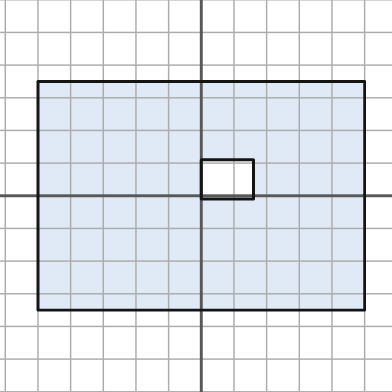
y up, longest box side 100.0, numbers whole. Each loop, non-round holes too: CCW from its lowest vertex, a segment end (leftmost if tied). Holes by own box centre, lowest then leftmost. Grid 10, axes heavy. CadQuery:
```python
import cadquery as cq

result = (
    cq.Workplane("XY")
    .moveTo(-50.0, -35.0)
    .lineTo(50.0, -35.0)
    .lineTo(50.0, 35.0)
    .lineTo(-50.0, 35.0)
    .close()
    .moveTo(0.0, -1.0)
    .lineTo(16.0, -1.0)
    .lineTo(16.0, 11.0)
    .lineTo(0.0, 11.0)
    .close()
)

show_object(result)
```